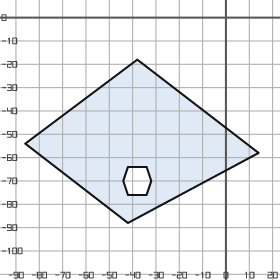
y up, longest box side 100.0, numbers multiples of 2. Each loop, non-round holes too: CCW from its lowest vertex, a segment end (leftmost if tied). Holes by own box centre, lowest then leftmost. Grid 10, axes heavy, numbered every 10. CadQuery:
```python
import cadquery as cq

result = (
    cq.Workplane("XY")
    .moveTo(-42.0, -88.0)
    .lineTo(14.0, -58.0)
    .lineTo(-38.0, -18.0)
    .lineTo(-86.0, -54.0)
    .close()
    .moveTo(-42.0, -76.0)
    .lineTo(-34.0, -76.0)
    .lineTo(-32.0, -70.0)
    .lineTo(-34.0, -64.0)
    .lineTo(-42.0, -64.0)
    .lineTo(-44.0, -70.0)
    .close()
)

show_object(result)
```